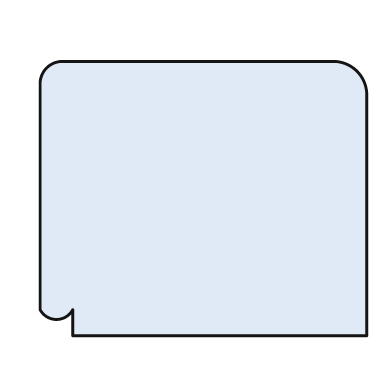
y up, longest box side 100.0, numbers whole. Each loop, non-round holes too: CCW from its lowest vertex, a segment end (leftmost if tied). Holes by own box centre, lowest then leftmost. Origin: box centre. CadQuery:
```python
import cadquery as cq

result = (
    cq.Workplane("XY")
    .moveTo(-40.0, -42.0)
    .lineTo(50.0, -42.0)
    .lineTo(50.0, 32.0)
    .threePointArc((47.0, 39.0), (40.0, 42.0))
    .lineTo(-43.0, 42.0)
    .threePointArc((-48.0, 40.0), (-50.0, 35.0))
    .lineTo(-50.0, -34.0)
    .threePointArc((-45.0, -37.0), (-40.0, -34.0))
    .close()
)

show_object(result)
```